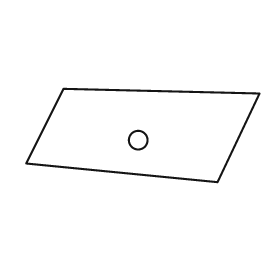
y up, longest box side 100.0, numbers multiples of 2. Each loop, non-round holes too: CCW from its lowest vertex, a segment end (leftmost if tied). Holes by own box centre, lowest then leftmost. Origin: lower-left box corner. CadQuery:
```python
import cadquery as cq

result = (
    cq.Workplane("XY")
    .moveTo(82.0, 0.0)
    .lineTo(100.0, 38.0)
    .lineTo(16.0, 40.0)
    .lineTo(0.0, 8.0)
    .close()
    .moveTo(48.0, 18.0)
    .circle(4.0)
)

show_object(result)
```